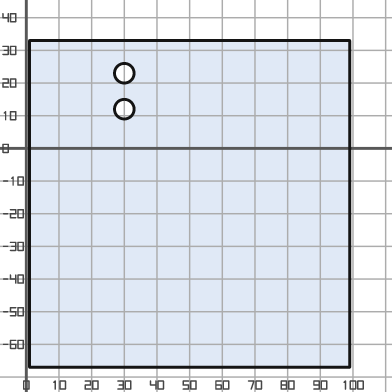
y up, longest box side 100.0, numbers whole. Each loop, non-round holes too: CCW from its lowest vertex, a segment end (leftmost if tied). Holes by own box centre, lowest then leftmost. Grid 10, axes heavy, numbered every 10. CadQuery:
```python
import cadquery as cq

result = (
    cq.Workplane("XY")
    .moveTo(1.0, -67.0)
    .lineTo(99.0, -67.0)
    .lineTo(99.0, 33.0)
    .lineTo(1.0, 33.0)
    .close()
    .moveTo(30.0, 12.0)
    .circle(3.0)
    .moveTo(30.0, 23.0)
    .circle(3.0)
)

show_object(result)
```